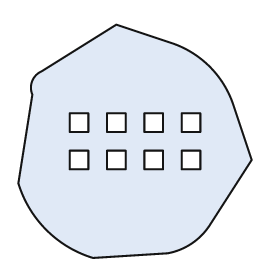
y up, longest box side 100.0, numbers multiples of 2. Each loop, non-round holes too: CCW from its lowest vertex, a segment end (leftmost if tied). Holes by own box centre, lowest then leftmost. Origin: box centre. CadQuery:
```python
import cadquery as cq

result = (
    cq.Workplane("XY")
    .moveTo(-18.0, -50.0)
    .lineTo(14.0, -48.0)
    .threePointArc((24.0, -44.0), (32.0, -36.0))
    .lineTo(50.0, -8.0)
    .lineTo(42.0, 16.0)
    .threePointArc((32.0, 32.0), (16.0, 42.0))
    .lineTo(-8.0, 50.0)
    .lineTo(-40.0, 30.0)
    .threePointArc((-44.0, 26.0), (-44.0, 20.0))
    .lineTo(-50.0, -18.0)
    .threePointArc((-38.0, -38.0), (-18.0, -50.0))
    .close()
    .moveTo(-28.0, -12.0)
    .lineTo(-20.0, -12.0)
    .lineTo(-20.0, -4.0)
    .lineTo(-28.0, -4.0)
    .close()
    .moveTo(-12.0, -12.0)
    .lineTo(-4.0, -12.0)
    .lineTo(-4.0, -4.0)
    .lineTo(-12.0, -4.0)
    .close()
    .moveTo(4.0, -12.0)
    .lineTo(12.0, -12.0)
    .lineTo(12.0, -4.0)
    .lineTo(4.0, -4.0)
    .close()
    .moveTo(20.0, -12.0)
    .lineTo(28.0, -12.0)
    .lineTo(28.0, -4.0)
    .lineTo(20.0, -4.0)
    .close()
    .moveTo(-28.0, 4.0)
    .lineTo(-20.0, 4.0)
    .lineTo(-20.0, 12.0)
    .lineTo(-28.0, 12.0)
    .close()
    .moveTo(-12.0, 4.0)
    .lineTo(-4.0, 4.0)
    .lineTo(-4.0, 12.0)
    .lineTo(-12.0, 12.0)
    .close()
    .moveTo(4.0, 4.0)
    .lineTo(12.0, 4.0)
    .lineTo(12.0, 12.0)
    .lineTo(4.0, 12.0)
    .close()
    .moveTo(20.0, 4.0)
    .lineTo(28.0, 4.0)
    .lineTo(28.0, 12.0)
    .lineTo(20.0, 12.0)
    .close()
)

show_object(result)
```